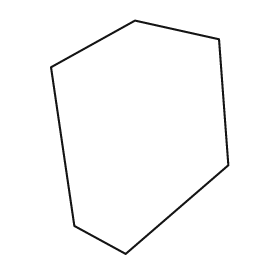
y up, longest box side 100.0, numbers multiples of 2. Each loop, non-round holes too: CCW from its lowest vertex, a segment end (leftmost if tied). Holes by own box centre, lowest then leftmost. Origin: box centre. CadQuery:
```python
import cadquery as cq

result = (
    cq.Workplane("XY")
    .moveTo(-6.0, -50.0)
    .lineTo(38.0, -12.0)
    .lineTo(34.0, 42.0)
    .lineTo(-2.0, 50.0)
    .lineTo(-38.0, 30.0)
    .lineTo(-28.0, -38.0)
    .close()
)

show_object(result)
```